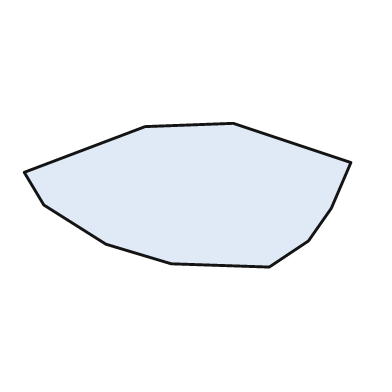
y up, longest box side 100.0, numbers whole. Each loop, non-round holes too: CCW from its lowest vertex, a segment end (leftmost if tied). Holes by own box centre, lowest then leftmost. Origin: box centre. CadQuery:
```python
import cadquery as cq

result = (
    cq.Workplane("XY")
    .moveTo(25.0, -22.0)
    .lineTo(37.0, -14.0)
    .lineTo(44.0, -4.0)
    .lineTo(50.0, 10.0)
    .lineTo(14.0, 22.0)
    .lineTo(-13.0, 21.0)
    .lineTo(-50.0, 7.0)
    .lineTo(-44.0, -3.0)
    .lineTo(-25.0, -15.0)
    .lineTo(-5.0, -21.0)
    .close()
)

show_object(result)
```